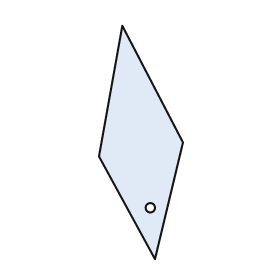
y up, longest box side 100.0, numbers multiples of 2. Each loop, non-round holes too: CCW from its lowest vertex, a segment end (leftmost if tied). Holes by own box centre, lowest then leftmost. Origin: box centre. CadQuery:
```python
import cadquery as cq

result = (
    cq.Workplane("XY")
    .moveTo(6.0, -50.0)
    .lineTo(18.0, 0.0)
    .lineTo(-8.0, 50.0)
    .lineTo(-18.0, -6.0)
    .close()
    .moveTo(4.0, -28.0)
    .circle(2.0)
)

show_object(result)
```